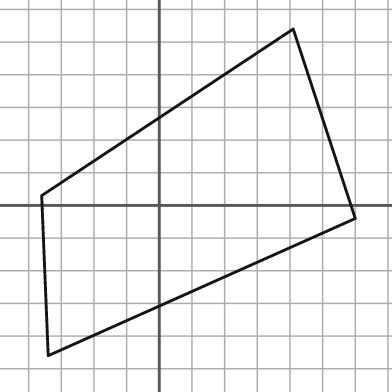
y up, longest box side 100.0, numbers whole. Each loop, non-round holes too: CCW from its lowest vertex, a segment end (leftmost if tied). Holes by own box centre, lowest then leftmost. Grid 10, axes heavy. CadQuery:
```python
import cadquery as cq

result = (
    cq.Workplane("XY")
    .moveTo(-34.0, -46.0)
    .lineTo(60.0, -4.0)
    .lineTo(41.0, 54.0)
    .lineTo(-36.0, 3.0)
    .close()
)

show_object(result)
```